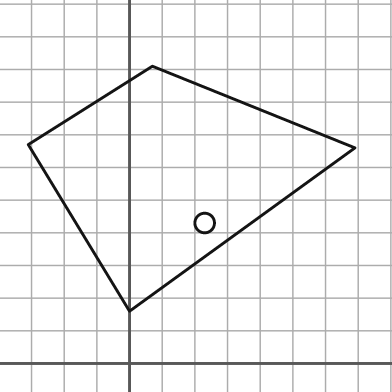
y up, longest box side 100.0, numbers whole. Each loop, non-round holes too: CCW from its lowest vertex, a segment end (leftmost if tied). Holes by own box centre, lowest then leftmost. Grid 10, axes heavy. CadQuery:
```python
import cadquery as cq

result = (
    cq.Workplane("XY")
    .moveTo(0.0, 16.0)
    .lineTo(69.0, 66.0)
    .lineTo(7.0, 91.0)
    .lineTo(-31.0, 67.0)
    .close()
    .moveTo(23.0, 43.0)
    .circle(3.0)
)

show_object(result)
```